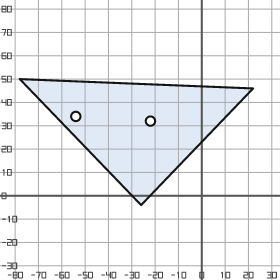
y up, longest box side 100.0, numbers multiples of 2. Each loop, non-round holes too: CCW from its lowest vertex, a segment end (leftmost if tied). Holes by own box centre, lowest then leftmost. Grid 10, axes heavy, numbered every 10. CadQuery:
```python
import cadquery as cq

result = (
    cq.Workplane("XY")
    .moveTo(-26.0, -4.0)
    .lineTo(22.0, 46.0)
    .lineTo(-78.0, 50.0)
    .close()
    .moveTo(-22.0, 32.0)
    .circle(2.0)
    .moveTo(-54.0, 34.0)
    .circle(2.0)
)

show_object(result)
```